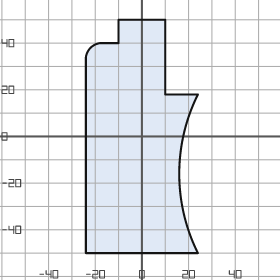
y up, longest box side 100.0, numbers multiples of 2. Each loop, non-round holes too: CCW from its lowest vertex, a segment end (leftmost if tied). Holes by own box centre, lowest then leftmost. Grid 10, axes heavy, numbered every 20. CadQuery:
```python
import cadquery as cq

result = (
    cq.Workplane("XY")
    .moveTo(-24.0, -50.0)
    .lineTo(24.0, -50.0)
    .threePointArc((16.0, -16.0), (24.0, 18.0))
    .lineTo(10.0, 18.0)
    .lineTo(10.0, 50.0)
    .lineTo(-10.0, 50.0)
    .lineTo(-10.0, 40.0)
    .lineTo(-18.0, 40.0)
    .threePointArc((-22.0, 38.0), (-24.0, 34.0))
    .close()
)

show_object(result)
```